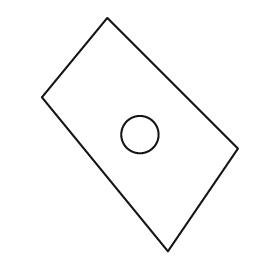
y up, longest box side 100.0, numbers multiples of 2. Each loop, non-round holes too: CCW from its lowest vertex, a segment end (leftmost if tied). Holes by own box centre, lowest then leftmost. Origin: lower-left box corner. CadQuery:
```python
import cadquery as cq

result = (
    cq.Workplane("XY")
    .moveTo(54.0, 0.0)
    .lineTo(84.0, 44.0)
    .lineTo(28.0, 100.0)
    .lineTo(0.0, 66.0)
    .close()
    .moveTo(42.0, 50.0)
    .circle(8.0)
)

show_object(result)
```